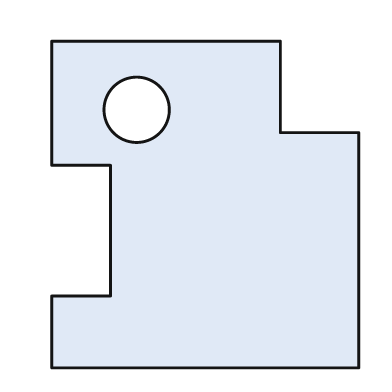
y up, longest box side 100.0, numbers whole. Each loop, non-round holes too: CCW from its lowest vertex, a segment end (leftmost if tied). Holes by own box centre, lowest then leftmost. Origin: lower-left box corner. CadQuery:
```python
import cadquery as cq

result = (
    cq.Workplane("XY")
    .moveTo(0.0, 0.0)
    .lineTo(94.0, 0.0)
    .lineTo(94.0, 72.0)
    .lineTo(70.0, 72.0)
    .lineTo(70.0, 100.0)
    .lineTo(0.0, 100.0)
    .lineTo(0.0, 62.0)
    .lineTo(18.0, 62.0)
    .lineTo(18.0, 22.0)
    .lineTo(0.0, 22.0)
    .close()
    .moveTo(26.0, 79.0)
    .circle(10.0)
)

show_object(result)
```